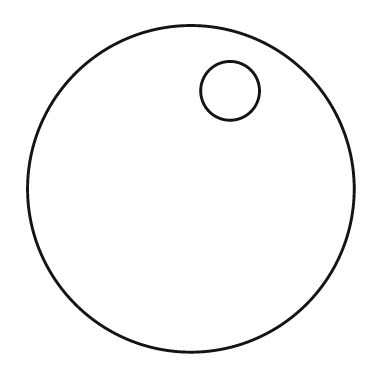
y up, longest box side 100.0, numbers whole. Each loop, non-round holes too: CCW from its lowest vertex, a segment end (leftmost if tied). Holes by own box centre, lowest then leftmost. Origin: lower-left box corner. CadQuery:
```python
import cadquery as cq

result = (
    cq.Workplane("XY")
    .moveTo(50.0, 50.0)
    .circle(50.0)
    .moveTo(62.0, 80.0)
    .circle(9.0)
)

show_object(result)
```